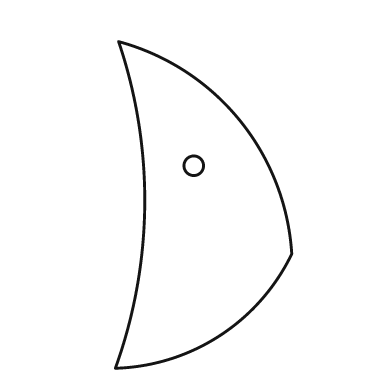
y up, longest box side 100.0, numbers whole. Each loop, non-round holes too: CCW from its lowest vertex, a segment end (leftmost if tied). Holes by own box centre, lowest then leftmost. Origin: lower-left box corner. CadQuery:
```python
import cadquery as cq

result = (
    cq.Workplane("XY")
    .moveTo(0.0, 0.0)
    .threePointArc((32.0, 10.0), (54.0, 35.0))
    .threePointArc((38.0, 76.0), (1.0, 100.0))
    .threePointArc((9.0, 50.0), (0.0, 0.0))
    .close()
    .moveTo(24.0, 62.0)
    .circle(3.0)
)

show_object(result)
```